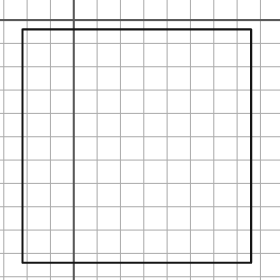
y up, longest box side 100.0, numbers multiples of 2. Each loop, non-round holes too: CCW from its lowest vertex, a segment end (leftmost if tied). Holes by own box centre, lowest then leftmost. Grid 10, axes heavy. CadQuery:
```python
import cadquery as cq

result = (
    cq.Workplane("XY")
    .moveTo(-22.0, -104.0)
    .lineTo(76.0, -104.0)
    .lineTo(76.0, -4.0)
    .lineTo(-22.0, -4.0)
    .close()
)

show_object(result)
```